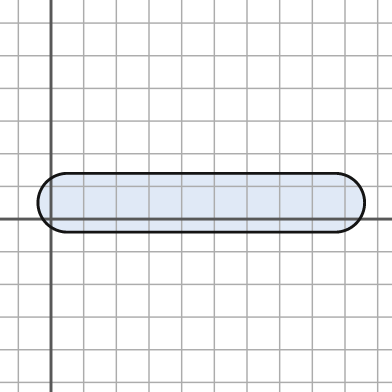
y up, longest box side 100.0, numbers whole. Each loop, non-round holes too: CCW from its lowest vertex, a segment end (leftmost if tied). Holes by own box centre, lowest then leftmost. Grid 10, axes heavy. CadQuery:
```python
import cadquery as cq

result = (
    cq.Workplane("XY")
    .moveTo(5.0, -4.0)
    .lineTo(87.0, -4.0)
    .threePointArc((96.0, 5.0), (87.0, 14.0))
    .lineTo(5.0, 14.0)
    .threePointArc((-4.0, 5.0), (5.0, -4.0))
    .close()
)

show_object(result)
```